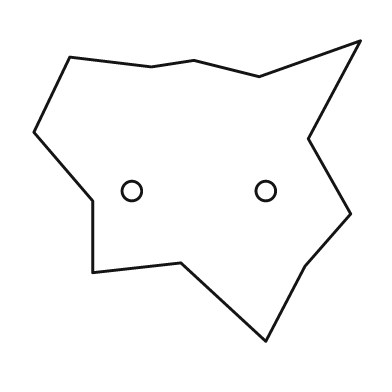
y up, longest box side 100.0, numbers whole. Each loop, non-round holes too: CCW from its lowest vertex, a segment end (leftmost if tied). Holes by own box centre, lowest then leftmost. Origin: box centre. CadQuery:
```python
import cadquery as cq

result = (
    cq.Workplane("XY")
    .moveTo(21.0, -46.0)
    .lineTo(33.0, -23.0)
    .lineTo(47.0, -7.0)
    .lineTo(34.0, 16.0)
    .lineTo(50.0, 46.0)
    .lineTo(19.0, 35.0)
    .lineTo(-1.0, 40.0)
    .lineTo(-14.0, 38.0)
    .lineTo(-39.0, 41.0)
    .lineTo(-50.0, 18.0)
    .lineTo(-32.0, -3.0)
    .lineTo(-32.0, -25.0)
    .lineTo(-5.0, -22.0)
    .close()
    .moveTo(-20.0, 0.0)
    .circle(3.0)
    .moveTo(21.0, 0.0)
    .circle(3.0)
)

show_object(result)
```